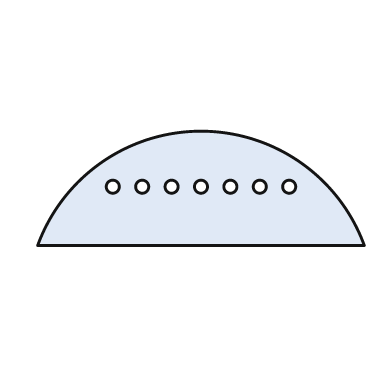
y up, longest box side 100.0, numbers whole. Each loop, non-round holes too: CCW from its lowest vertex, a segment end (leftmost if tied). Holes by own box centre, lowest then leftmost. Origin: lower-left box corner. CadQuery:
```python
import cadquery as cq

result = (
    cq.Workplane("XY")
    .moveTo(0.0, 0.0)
    .lineTo(100.0, 0.0)
    .threePointArc((50.0, 35.0), (0.0, 0.0))
    .close()
    .moveTo(23.0, 18.0)
    .circle(2.0)
    .moveTo(32.0, 18.0)
    .circle(2.0)
    .moveTo(41.0, 18.0)
    .circle(2.0)
    .moveTo(50.0, 18.0)
    .circle(2.0)
    .moveTo(59.0, 18.0)
    .circle(2.0)
    .moveTo(68.0, 18.0)
    .circle(2.0)
    .moveTo(77.0, 18.0)
    .circle(2.0)
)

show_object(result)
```